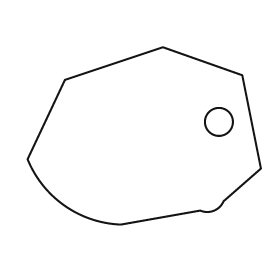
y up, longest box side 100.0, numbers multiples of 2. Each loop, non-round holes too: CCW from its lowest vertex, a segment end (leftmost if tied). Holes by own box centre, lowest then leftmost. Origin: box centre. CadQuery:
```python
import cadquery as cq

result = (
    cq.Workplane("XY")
    .moveTo(-10.0, -38.0)
    .lineTo(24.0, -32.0)
    .threePointArc((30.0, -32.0), (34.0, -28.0))
    .lineTo(50.0, -14.0)
    .lineTo(42.0, 26.0)
    .lineTo(8.0, 38.0)
    .lineTo(-34.0, 24.0)
    .lineTo(-50.0, -10.0)
    .threePointArc((-34.0, -30.0), (-10.0, -38.0))
    .close()
    .moveTo(32.0, 6.0)
    .circle(6.0)
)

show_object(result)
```